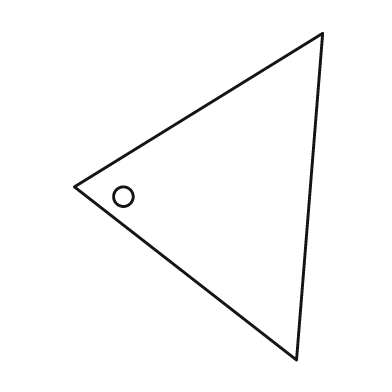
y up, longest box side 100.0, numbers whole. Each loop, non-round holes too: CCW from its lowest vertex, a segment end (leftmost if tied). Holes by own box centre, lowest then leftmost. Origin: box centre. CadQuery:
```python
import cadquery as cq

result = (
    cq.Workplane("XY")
    .moveTo(30.0, -50.0)
    .lineTo(38.0, 50.0)
    .lineTo(-38.0, 3.0)
    .close()
    .moveTo(-23.0, 0.0)
    .circle(3.0)
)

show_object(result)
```